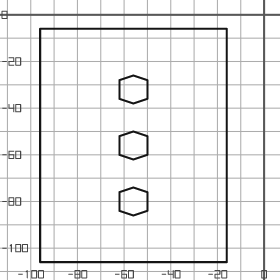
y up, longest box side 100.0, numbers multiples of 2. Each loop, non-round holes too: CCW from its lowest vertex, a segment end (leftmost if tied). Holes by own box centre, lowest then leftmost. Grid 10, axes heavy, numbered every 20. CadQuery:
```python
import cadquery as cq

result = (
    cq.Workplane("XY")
    .moveTo(-96.0, -106.0)
    .lineTo(-16.0, -106.0)
    .lineTo(-16.0, -6.0)
    .lineTo(-96.0, -6.0)
    .close()
    .moveTo(-56.0, -86.0)
    .lineTo(-50.0, -84.0)
    .lineTo(-50.0, -76.0)
    .lineTo(-56.0, -74.0)
    .lineTo(-62.0, -76.0)
    .lineTo(-62.0, -84.0)
    .close()
    .moveTo(-56.0, -62.0)
    .lineTo(-50.0, -60.0)
    .lineTo(-50.0, -52.0)
    .lineTo(-56.0, -50.0)
    .lineTo(-62.0, -52.0)
    .lineTo(-62.0, -60.0)
    .close()
    .moveTo(-56.0, -38.0)
    .lineTo(-50.0, -36.0)
    .lineTo(-50.0, -28.0)
    .lineTo(-56.0, -26.0)
    .lineTo(-62.0, -28.0)
    .lineTo(-62.0, -36.0)
    .close()
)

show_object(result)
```